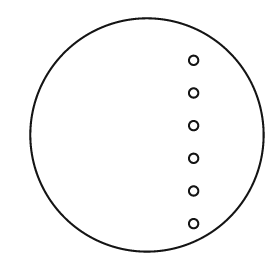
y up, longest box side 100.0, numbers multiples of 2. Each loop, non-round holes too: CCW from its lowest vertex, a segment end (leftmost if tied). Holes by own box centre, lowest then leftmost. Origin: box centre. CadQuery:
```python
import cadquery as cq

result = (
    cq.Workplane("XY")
    .moveTo(0.0, 0.0)
    .circle(50.0)
    .moveTo(20.0, -38.0)
    .circle(2.0)
    .moveTo(20.0, -24.0)
    .circle(2.0)
    .moveTo(20.0, -10.0)
    .circle(2.0)
    .moveTo(20.0, 4.0)
    .circle(2.0)
    .moveTo(20.0, 18.0)
    .circle(2.0)
    .moveTo(20.0, 32.0)
    .circle(2.0)
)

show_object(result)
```